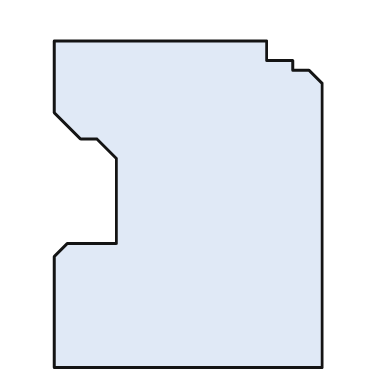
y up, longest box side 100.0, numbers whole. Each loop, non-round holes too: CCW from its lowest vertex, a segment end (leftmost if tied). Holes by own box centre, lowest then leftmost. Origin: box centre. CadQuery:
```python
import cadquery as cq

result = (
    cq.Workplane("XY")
    .moveTo(-41.0, -50.0)
    .lineTo(41.0, -50.0)
    .lineTo(41.0, 37.0)
    .lineTo(37.0, 41.0)
    .lineTo(32.0, 41.0)
    .lineTo(32.0, 44.0)
    .lineTo(24.0, 44.0)
    .lineTo(24.0, 50.0)
    .lineTo(-41.0, 50.0)
    .lineTo(-41.0, 28.0)
    .lineTo(-33.0, 20.0)
    .lineTo(-28.0, 20.0)
    .lineTo(-22.0, 14.0)
    .lineTo(-22.0, -12.0)
    .lineTo(-37.0, -12.0)
    .lineTo(-41.0, -16.0)
    .close()
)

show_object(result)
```